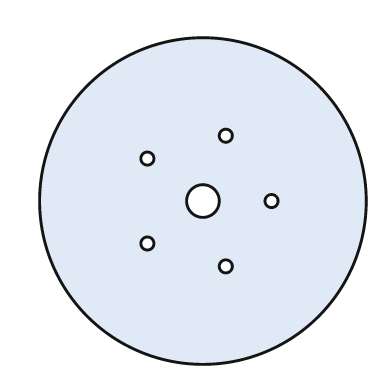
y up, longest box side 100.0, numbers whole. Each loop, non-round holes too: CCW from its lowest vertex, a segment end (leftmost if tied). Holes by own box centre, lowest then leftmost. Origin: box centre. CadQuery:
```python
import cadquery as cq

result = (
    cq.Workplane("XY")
    .moveTo(0.0, 0.0)
    .circle(50.0)
    .moveTo(7.0, -20.0)
    .circle(2.0)
    .moveTo(-17.0, -13.0)
    .circle(2.0)
    .moveTo(0.0, 0.0)
    .circle(5.0)
    .moveTo(21.0, 0.0)
    .circle(2.0)
    .moveTo(-17.0, 13.0)
    .circle(2.0)
    .moveTo(7.0, 20.0)
    .circle(2.0)
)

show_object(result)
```